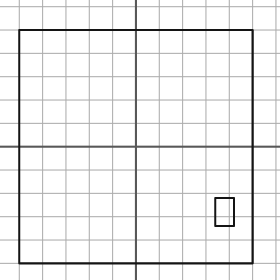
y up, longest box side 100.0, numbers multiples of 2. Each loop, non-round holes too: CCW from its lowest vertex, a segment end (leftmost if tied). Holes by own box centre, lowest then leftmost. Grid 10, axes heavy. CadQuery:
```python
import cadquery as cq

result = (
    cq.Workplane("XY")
    .moveTo(-50.0, -50.0)
    .lineTo(50.0, -50.0)
    .lineTo(50.0, 50.0)
    .lineTo(-50.0, 50.0)
    .close()
    .moveTo(34.0, -34.0)
    .lineTo(42.0, -34.0)
    .lineTo(42.0, -22.0)
    .lineTo(34.0, -22.0)
    .close()
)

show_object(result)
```